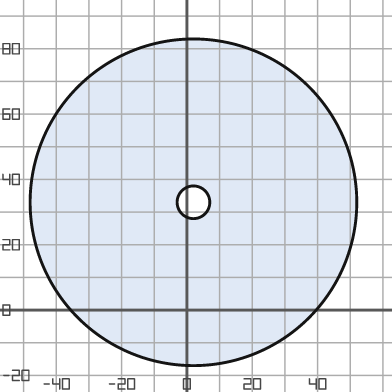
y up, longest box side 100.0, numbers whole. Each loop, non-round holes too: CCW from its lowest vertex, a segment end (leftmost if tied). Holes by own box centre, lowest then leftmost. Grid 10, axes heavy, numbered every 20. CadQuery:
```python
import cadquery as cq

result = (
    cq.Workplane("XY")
    .moveTo(2.0, 33.0)
    .circle(50.0)
    .moveTo(2.0, 33.0)
    .circle(5.0)
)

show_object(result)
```